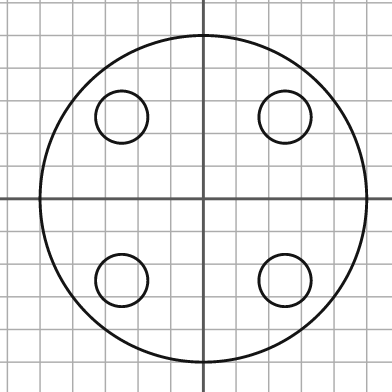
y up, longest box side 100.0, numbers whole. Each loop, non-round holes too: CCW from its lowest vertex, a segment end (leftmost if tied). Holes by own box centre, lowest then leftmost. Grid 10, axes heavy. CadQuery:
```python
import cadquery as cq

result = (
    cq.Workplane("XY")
    .moveTo(0.0, 0.0)
    .circle(50.0)
    .moveTo(-25.0, -25.0)
    .circle(8.0)
    .moveTo(25.0, -25.0)
    .circle(8.0)
    .moveTo(-25.0, 25.0)
    .circle(8.0)
    .moveTo(25.0, 25.0)
    .circle(8.0)
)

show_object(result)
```